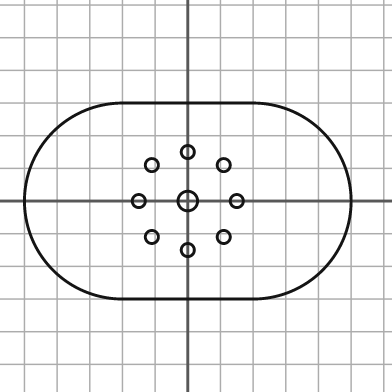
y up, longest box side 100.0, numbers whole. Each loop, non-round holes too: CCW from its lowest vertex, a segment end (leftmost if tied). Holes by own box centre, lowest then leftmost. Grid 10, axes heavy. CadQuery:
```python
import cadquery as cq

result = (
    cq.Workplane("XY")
    .moveTo(-20.0, -30.0)
    .lineTo(20.0, -30.0)
    .threePointArc((50.0, 0.0), (20.0, 30.0))
    .lineTo(-20.0, 30.0)
    .threePointArc((-50.0, 0.0), (-20.0, -30.0))
    .close()
    .moveTo(0.0, -15.0)
    .circle(2.0)
    .moveTo(-11.0, -11.0)
    .circle(2.0)
    .moveTo(11.0, -11.0)
    .circle(2.0)
    .moveTo(-15.0, 0.0)
    .circle(2.0)
    .moveTo(0.0, 0.0)
    .circle(3.0)
    .moveTo(15.0, 0.0)
    .circle(2.0)
    .moveTo(-11.0, 11.0)
    .circle(2.0)
    .moveTo(11.0, 11.0)
    .circle(2.0)
    .moveTo(0.0, 15.0)
    .circle(2.0)
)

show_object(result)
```